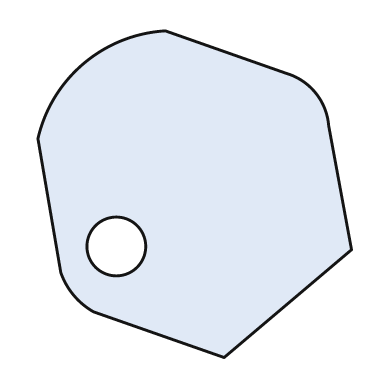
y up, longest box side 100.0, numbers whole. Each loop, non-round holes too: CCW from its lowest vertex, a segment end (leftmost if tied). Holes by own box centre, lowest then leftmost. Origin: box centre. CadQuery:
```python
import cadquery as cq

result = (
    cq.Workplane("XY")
    .moveTo(9.0, -50.0)
    .lineTo(48.0, -17.0)
    .lineTo(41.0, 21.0)
    .threePointArc((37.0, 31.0), (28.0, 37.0))
    .lineTo(-9.0, 50.0)
    .threePointArc((-34.0, 40.0), (-48.0, 17.0))
    .lineTo(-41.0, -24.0)
    .threePointArc((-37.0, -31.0), (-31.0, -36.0))
    .close()
    .moveTo(-24.0, -16.0)
    .circle(9.0)
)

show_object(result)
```